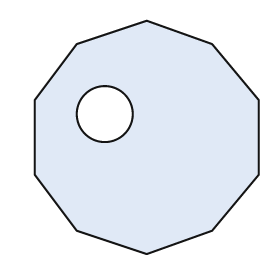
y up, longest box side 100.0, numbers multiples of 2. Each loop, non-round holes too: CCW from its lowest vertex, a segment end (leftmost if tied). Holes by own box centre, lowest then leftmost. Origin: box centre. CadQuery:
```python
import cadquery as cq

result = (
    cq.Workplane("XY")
    .moveTo(0.0, -50.0)
    .lineTo(28.0, -40.0)
    .lineTo(48.0, -16.0)
    .lineTo(48.0, 16.0)
    .lineTo(28.0, 40.0)
    .lineTo(0.0, 50.0)
    .lineTo(-30.0, 40.0)
    .lineTo(-48.0, 16.0)
    .lineTo(-48.0, -16.0)
    .lineTo(-30.0, -40.0)
    .close()
    .moveTo(-18.0, 10.0)
    .circle(12.0)
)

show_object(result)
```